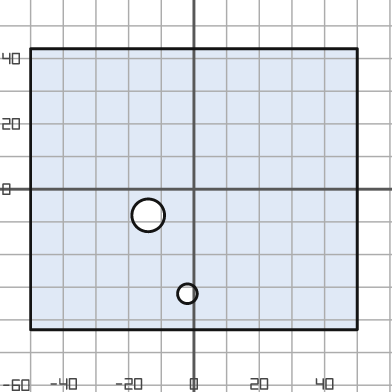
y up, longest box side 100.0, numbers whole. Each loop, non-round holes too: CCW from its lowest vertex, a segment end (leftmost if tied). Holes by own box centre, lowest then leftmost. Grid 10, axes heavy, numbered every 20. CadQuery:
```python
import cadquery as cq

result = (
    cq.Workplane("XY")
    .moveTo(-50.0, -43.0)
    .lineTo(50.0, -43.0)
    .lineTo(50.0, 43.0)
    .lineTo(-50.0, 43.0)
    .close()
    .moveTo(-2.0, -32.0)
    .circle(3.0)
    .moveTo(-14.0, -8.0)
    .circle(5.0)
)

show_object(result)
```